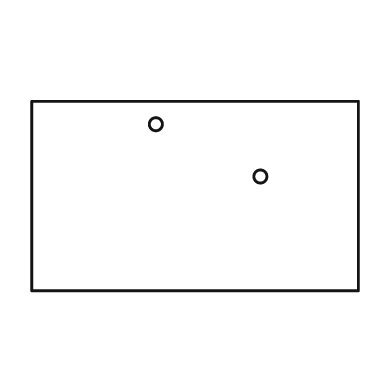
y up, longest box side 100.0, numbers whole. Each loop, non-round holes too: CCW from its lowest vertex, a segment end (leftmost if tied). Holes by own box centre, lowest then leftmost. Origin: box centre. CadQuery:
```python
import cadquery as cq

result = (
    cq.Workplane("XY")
    .moveTo(-50.0, -29.0)
    .lineTo(50.0, -29.0)
    .lineTo(50.0, 29.0)
    .lineTo(-50.0, 29.0)
    .close()
    .moveTo(20.0, 6.0)
    .circle(2.0)
    .moveTo(-12.0, 22.0)
    .circle(2.0)
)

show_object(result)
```